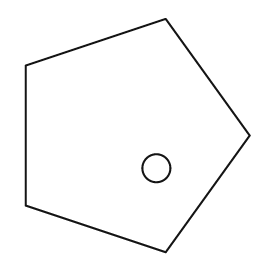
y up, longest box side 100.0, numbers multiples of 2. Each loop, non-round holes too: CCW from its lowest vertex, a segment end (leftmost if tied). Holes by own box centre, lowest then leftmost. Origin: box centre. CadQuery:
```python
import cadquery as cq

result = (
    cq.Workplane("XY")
    .moveTo(12.0, -50.0)
    .lineTo(48.0, 0.0)
    .lineTo(12.0, 50.0)
    .lineTo(-48.0, 30.0)
    .lineTo(-48.0, -30.0)
    .close()
    .moveTo(8.0, -14.0)
    .circle(6.0)
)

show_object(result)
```